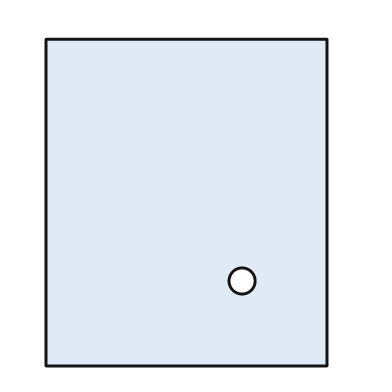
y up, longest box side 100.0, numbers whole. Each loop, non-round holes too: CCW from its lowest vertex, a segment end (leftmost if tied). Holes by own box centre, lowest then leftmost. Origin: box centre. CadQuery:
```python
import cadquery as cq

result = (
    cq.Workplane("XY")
    .moveTo(-43.0, -50.0)
    .lineTo(43.0, -50.0)
    .lineTo(43.0, 50.0)
    .lineTo(-43.0, 50.0)
    .close()
    .moveTo(17.0, -24.0)
    .circle(4.0)
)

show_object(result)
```